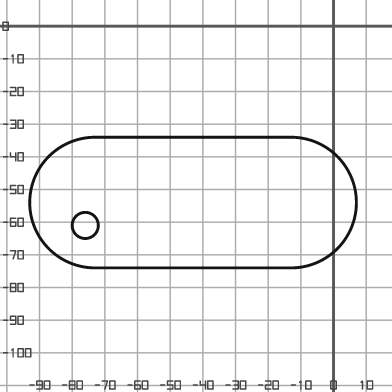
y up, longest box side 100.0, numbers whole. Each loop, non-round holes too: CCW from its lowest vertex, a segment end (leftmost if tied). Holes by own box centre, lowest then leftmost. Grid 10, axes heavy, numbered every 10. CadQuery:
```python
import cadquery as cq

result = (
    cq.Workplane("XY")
    .moveTo(-73.0, -74.0)
    .lineTo(-13.0, -74.0)
    .threePointArc((7.0, -54.0), (-13.0, -34.0))
    .lineTo(-73.0, -34.0)
    .threePointArc((-93.0, -54.0), (-73.0, -74.0))
    .close()
    .moveTo(-76.0, -61.0)
    .circle(4.0)
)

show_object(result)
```